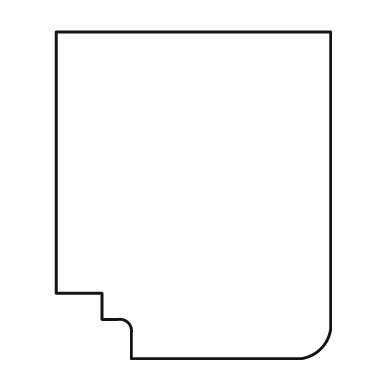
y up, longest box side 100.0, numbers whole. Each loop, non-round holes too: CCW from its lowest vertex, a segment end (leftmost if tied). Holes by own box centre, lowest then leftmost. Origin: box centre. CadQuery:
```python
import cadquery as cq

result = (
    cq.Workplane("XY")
    .moveTo(-19.0, -50.0)
    .lineTo(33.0, -50.0)
    .threePointArc((39.0, -47.0), (42.0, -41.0))
    .lineTo(42.0, 50.0)
    .lineTo(-42.0, 50.0)
    .lineTo(-42.0, -30.0)
    .lineTo(-28.0, -30.0)
    .lineTo(-28.0, -38.0)
    .lineTo(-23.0, -38.0)
    .threePointArc((-20.0, -39.0), (-19.0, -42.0))
    .close()
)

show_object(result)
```